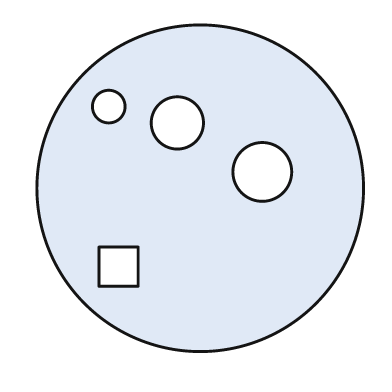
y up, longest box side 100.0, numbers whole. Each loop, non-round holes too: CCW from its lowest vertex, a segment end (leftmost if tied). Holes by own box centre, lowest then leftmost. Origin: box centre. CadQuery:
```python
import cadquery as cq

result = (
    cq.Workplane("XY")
    .moveTo(0.0, 0.0)
    .circle(50.0)
    .moveTo(-31.0, -30.0)
    .lineTo(-19.0, -30.0)
    .lineTo(-19.0, -18.0)
    .lineTo(-31.0, -18.0)
    .close()
    .moveTo(19.0, 5.0)
    .circle(9.0)
    .moveTo(-7.0, 20.0)
    .circle(8.0)
    .moveTo(-28.0, 25.0)
    .circle(5.0)
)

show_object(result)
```